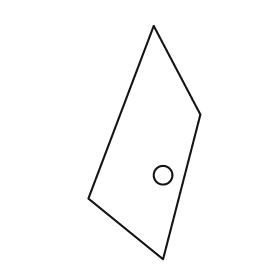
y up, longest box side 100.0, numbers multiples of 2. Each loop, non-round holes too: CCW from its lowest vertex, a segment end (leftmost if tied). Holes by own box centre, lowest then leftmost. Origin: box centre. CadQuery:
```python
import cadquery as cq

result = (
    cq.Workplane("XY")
    .moveTo(8.0, -50.0)
    .lineTo(24.0, 12.0)
    .lineTo(4.0, 50.0)
    .lineTo(-24.0, -24.0)
    .close()
    .moveTo(8.0, -14.0)
    .circle(4.0)
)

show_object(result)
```